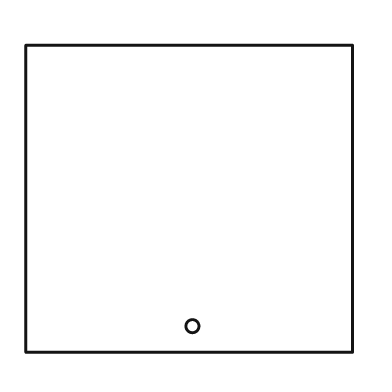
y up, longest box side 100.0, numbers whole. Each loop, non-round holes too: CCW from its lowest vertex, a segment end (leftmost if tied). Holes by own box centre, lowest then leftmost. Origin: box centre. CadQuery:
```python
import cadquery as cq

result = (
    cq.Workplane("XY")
    .moveTo(-50.0, -47.0)
    .lineTo(50.0, -47.0)
    .lineTo(50.0, 47.0)
    .lineTo(-50.0, 47.0)
    .close()
    .moveTo(1.0, -39.0)
    .circle(2.0)
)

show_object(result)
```